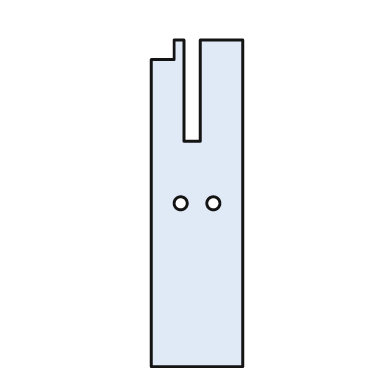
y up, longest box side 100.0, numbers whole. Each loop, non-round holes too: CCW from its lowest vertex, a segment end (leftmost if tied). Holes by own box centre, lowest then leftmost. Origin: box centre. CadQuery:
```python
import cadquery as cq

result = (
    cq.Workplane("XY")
    .moveTo(-14.0, -50.0)
    .lineTo(14.0, -50.0)
    .lineTo(14.0, 50.0)
    .lineTo(1.0, 50.0)
    .lineTo(1.0, 19.0)
    .lineTo(-4.0, 19.0)
    .lineTo(-4.0, 50.0)
    .lineTo(-7.0, 50.0)
    .lineTo(-7.0, 44.0)
    .lineTo(-14.0, 44.0)
    .close()
    .moveTo(-5.0, 0.0)
    .circle(2.0)
    .moveTo(5.0, 0.0)
    .circle(2.0)
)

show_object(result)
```